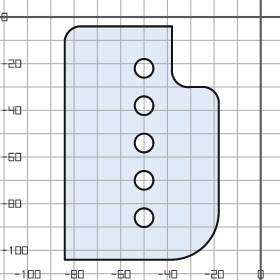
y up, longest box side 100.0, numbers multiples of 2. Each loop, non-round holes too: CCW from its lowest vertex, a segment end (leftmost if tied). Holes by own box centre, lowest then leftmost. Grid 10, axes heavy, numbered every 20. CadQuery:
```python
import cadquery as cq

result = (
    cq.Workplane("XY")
    .moveTo(-84.0, -104.0)
    .lineTo(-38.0, -104.0)
    .threePointArc((-24.0, -98.0), (-18.0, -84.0))
    .lineTo(-18.0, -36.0)
    .threePointArc((-20.0, -32.0), (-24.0, -30.0))
    .lineTo(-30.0, -30.0)
    .threePointArc((-36.0, -28.0), (-38.0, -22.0))
    .lineTo(-38.0, -4.0)
    .lineTo(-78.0, -4.0)
    .threePointArc((-82.0, -6.0), (-84.0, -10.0))
    .close()
    .moveTo(-50.0, -86.0)
    .circle(4.0)
    .moveTo(-50.0, -70.0)
    .circle(4.0)
    .moveTo(-50.0, -54.0)
    .circle(4.0)
    .moveTo(-50.0, -38.0)
    .circle(4.0)
    .moveTo(-50.0, -22.0)
    .circle(4.0)
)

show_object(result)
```